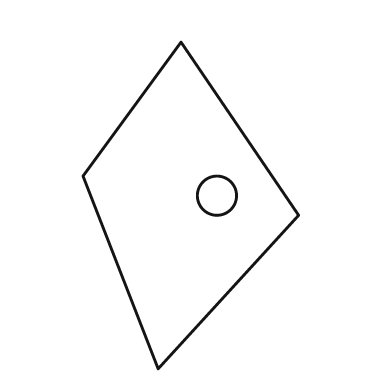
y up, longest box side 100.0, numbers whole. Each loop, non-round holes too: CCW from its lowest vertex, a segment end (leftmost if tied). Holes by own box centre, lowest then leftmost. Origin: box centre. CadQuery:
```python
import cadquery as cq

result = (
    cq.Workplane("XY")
    .moveTo(-10.0, -50.0)
    .lineTo(33.0, -3.0)
    .lineTo(-3.0, 50.0)
    .lineTo(-33.0, 9.0)
    .close()
    .moveTo(8.0, 3.0)
    .circle(6.0)
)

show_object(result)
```